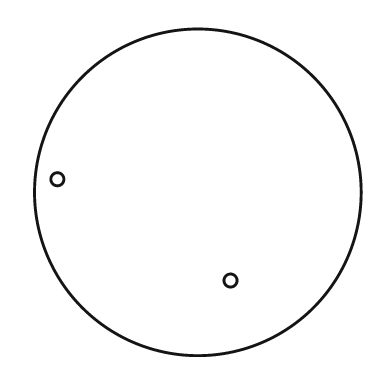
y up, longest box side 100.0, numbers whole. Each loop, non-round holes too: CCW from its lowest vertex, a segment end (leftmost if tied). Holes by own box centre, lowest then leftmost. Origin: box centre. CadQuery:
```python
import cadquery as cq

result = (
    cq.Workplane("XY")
    .moveTo(0.0, 0.0)
    .circle(50.0)
    .moveTo(10.0, -27.0)
    .circle(2.0)
    .moveTo(-43.0, 4.0)
    .circle(2.0)
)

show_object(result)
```